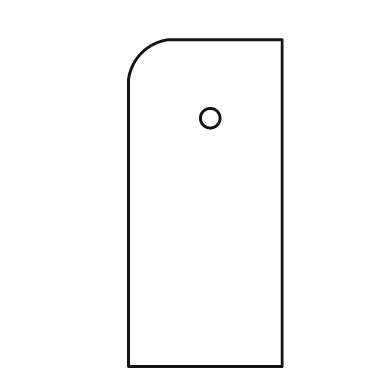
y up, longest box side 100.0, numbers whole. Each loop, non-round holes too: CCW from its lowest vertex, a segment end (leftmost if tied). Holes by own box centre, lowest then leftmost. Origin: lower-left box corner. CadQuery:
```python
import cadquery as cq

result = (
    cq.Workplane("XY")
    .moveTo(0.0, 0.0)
    .lineTo(47.0, 0.0)
    .lineTo(47.0, 100.0)
    .lineTo(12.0, 100.0)
    .threePointArc((4.0, 96.0), (0.0, 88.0))
    .close()
    .moveTo(25.0, 76.0)
    .circle(3.0)
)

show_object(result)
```